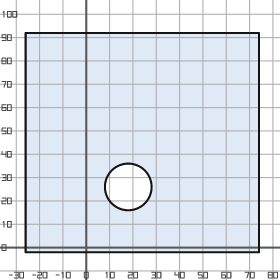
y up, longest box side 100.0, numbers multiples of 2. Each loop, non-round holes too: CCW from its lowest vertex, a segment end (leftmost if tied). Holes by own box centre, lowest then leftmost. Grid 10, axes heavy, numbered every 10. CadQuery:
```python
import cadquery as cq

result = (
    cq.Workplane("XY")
    .moveTo(-26.0, -2.0)
    .lineTo(74.0, -2.0)
    .lineTo(74.0, 92.0)
    .lineTo(-26.0, 92.0)
    .close()
    .moveTo(18.0, 26.0)
    .circle(10.0)
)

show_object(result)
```